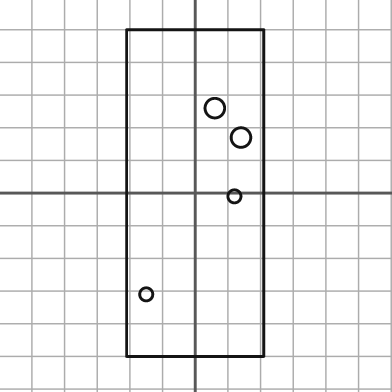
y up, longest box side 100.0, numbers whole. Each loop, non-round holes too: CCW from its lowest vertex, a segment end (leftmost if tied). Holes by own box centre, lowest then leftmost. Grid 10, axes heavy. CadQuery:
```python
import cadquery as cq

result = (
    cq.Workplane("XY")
    .moveTo(-21.0, -50.0)
    .lineTo(21.0, -50.0)
    .lineTo(21.0, 50.0)
    .lineTo(-21.0, 50.0)
    .close()
    .moveTo(-15.0, -31.0)
    .circle(2.0)
    .moveTo(12.0, -1.0)
    .circle(2.0)
    .moveTo(14.0, 17.0)
    .circle(3.0)
    .moveTo(6.0, 26.0)
    .circle(3.0)
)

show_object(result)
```